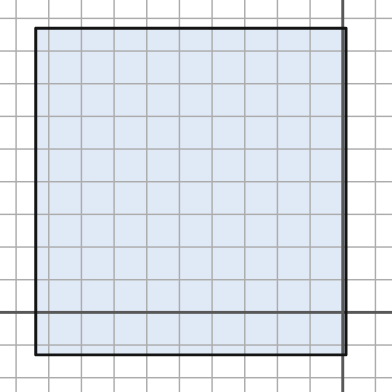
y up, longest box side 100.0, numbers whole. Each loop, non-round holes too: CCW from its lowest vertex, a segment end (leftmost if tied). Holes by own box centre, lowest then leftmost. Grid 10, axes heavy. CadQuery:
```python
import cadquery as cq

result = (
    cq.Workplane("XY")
    .moveTo(-94.0, -13.0)
    .lineTo(1.0, -13.0)
    .lineTo(1.0, 87.0)
    .lineTo(-94.0, 87.0)
    .close()
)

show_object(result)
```